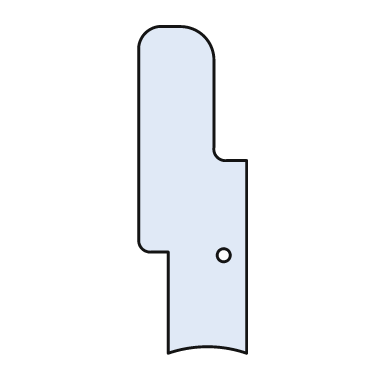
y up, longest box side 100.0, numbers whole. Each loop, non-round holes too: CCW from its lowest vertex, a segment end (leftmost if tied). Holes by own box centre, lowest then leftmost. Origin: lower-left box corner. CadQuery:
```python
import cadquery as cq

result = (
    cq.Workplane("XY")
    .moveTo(9.0, 0.0)
    .threePointArc((21.0, 2.0), (33.0, 0.0))
    .lineTo(33.0, 59.0)
    .lineTo(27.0, 59.0)
    .threePointArc((24.0, 60.0), (23.0, 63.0))
    .lineTo(23.0, 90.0)
    .threePointArc((20.0, 97.0), (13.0, 100.0))
    .lineTo(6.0, 100.0)
    .threePointArc((2.0, 98.0), (0.0, 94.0))
    .lineTo(0.0, 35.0)
    .threePointArc((1.0, 32.0), (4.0, 31.0))
    .lineTo(9.0, 31.0)
    .close()
    .moveTo(26.0, 30.0)
    .circle(2.0)
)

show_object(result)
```